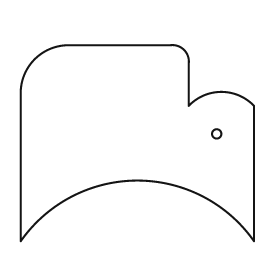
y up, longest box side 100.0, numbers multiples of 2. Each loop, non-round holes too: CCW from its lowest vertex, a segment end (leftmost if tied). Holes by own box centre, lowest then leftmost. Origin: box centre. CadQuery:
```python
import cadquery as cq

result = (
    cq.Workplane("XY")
    .moveTo(-50.0, -42.0)
    .threePointArc((0.0, -16.0), (50.0, -42.0))
    .lineTo(50.0, 16.0)
    .threePointArc((36.0, 22.0), (22.0, 16.0))
    .lineTo(22.0, 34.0)
    .threePointArc((20.0, 40.0), (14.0, 42.0))
    .lineTo(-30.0, 42.0)
    .threePointArc((-44.0, 36.0), (-50.0, 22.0))
    .close()
    .moveTo(34.0, 4.0)
    .circle(2.0)
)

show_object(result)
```